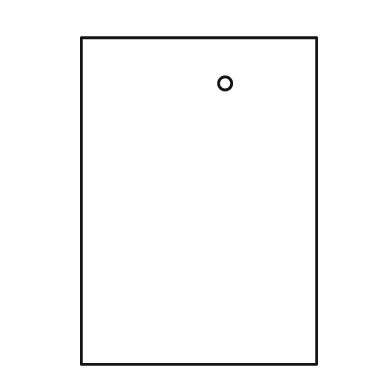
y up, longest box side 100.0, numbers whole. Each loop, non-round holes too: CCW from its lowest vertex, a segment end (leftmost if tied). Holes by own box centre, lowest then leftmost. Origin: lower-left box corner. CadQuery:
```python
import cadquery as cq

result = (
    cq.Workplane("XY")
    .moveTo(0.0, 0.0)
    .lineTo(72.0, 0.0)
    .lineTo(72.0, 100.0)
    .lineTo(0.0, 100.0)
    .close()
    .moveTo(44.0, 86.0)
    .circle(2.0)
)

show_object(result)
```